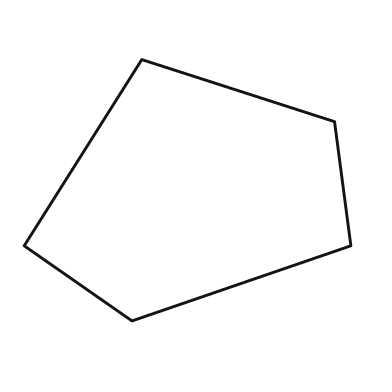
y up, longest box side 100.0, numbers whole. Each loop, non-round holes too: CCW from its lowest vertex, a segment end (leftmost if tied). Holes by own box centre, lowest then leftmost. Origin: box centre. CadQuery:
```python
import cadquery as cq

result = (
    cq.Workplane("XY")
    .moveTo(-17.0, -40.0)
    .lineTo(50.0, -17.0)
    .lineTo(45.0, 21.0)
    .lineTo(-14.0, 40.0)
    .lineTo(-50.0, -17.0)
    .close()
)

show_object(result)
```